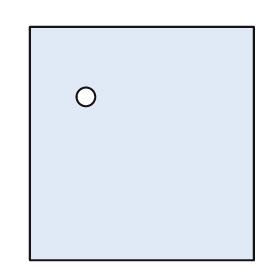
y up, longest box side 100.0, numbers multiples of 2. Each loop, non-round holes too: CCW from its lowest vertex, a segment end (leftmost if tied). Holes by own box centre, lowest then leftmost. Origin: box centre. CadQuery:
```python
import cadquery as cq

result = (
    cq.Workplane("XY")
    .moveTo(-48.0, -50.0)
    .lineTo(48.0, -50.0)
    .lineTo(48.0, 50.0)
    .lineTo(-48.0, 50.0)
    .close()
    .moveTo(-24.0, 20.0)
    .circle(4.0)
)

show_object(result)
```